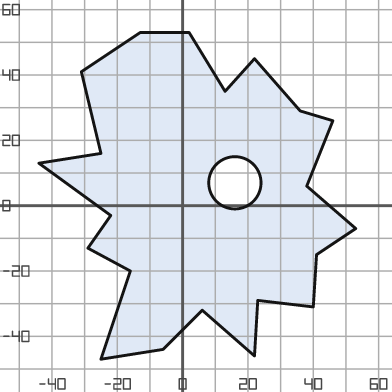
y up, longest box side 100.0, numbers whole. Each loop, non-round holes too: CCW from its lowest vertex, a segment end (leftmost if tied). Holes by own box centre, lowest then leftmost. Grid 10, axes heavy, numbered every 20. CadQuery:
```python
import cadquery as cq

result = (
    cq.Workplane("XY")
    .moveTo(-25.0, -47.0)
    .lineTo(-6.0, -44.0)
    .lineTo(6.0, -32.0)
    .lineTo(22.0, -46.0)
    .lineTo(23.0, -29.0)
    .lineTo(40.0, -31.0)
    .lineTo(41.0, -15.0)
    .lineTo(53.0, -7.0)
    .lineTo(38.0, 6.0)
    .lineTo(46.0, 26.0)
    .lineTo(36.0, 29.0)
    .lineTo(22.0, 45.0)
    .lineTo(13.0, 35.0)
    .lineTo(2.0, 53.0)
    .lineTo(-13.0, 53.0)
    .lineTo(-31.0, 41.0)
    .lineTo(-25.0, 16.0)
    .lineTo(-44.0, 13.0)
    .lineTo(-22.0, -3.0)
    .lineTo(-29.0, -13.0)
    .lineTo(-16.0, -20.0)
    .close()
    .moveTo(16.0, 7.0)
    .circle(8.0)
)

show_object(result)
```